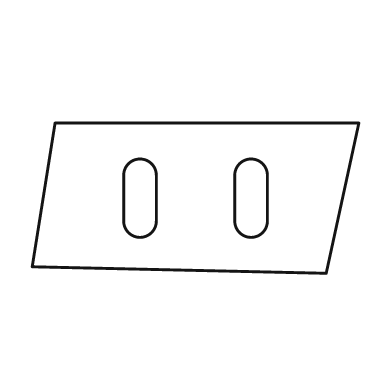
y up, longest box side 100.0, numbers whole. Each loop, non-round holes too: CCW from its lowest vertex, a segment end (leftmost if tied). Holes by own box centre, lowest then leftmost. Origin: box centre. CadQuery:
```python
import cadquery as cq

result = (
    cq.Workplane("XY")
    .moveTo(40.0, -23.0)
    .lineTo(50.0, 23.0)
    .lineTo(-43.0, 23.0)
    .lineTo(-50.0, -21.0)
    .close()
    .moveTo(-22.0, -7.0)
    .threePointArc((-17.0, -12.0), (-12.0, -7.0))
    .lineTo(-12.0, 7.0)
    .threePointArc((-17.0, 12.0), (-22.0, 7.0))
    .close()
    .moveTo(12.0, -7.0)
    .threePointArc((17.0, -12.0), (22.0, -7.0))
    .lineTo(22.0, 7.0)
    .threePointArc((17.0, 12.0), (12.0, 7.0))
    .close()
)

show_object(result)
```